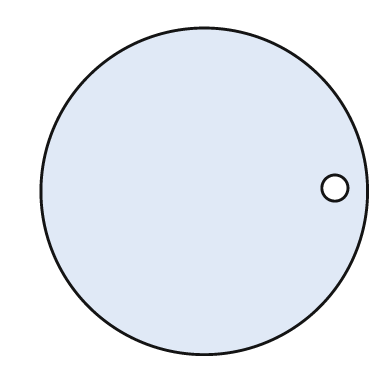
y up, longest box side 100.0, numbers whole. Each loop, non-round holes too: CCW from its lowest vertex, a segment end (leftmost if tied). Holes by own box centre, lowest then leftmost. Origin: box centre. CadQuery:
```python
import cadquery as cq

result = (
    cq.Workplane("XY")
    .moveTo(0.0, 0.0)
    .circle(50.0)
    .moveTo(40.0, 1.0)
    .circle(4.0)
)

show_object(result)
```